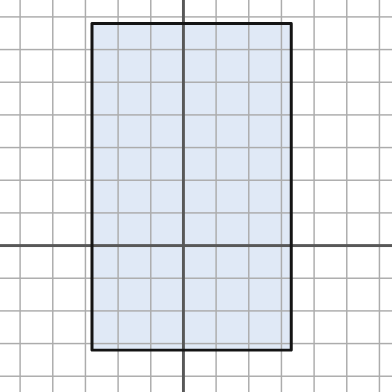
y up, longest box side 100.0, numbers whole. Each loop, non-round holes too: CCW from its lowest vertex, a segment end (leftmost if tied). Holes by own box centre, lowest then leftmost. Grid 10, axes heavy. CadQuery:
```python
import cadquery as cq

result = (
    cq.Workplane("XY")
    .moveTo(-28.0, -32.0)
    .lineTo(33.0, -32.0)
    .lineTo(33.0, 68.0)
    .lineTo(-28.0, 68.0)
    .close()
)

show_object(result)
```